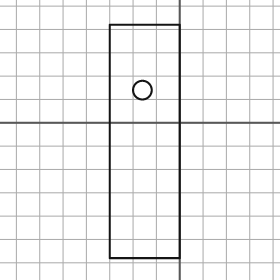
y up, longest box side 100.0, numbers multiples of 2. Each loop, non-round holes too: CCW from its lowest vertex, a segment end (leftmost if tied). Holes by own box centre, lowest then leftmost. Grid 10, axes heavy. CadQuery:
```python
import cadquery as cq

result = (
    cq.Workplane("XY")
    .moveTo(-30.0, -58.0)
    .lineTo(0.0, -58.0)
    .lineTo(0.0, 42.0)
    .lineTo(-30.0, 42.0)
    .close()
    .moveTo(-16.0, 14.0)
    .circle(4.0)
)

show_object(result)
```